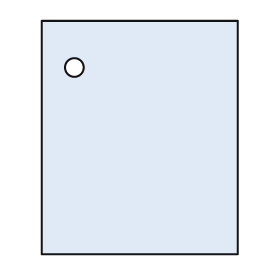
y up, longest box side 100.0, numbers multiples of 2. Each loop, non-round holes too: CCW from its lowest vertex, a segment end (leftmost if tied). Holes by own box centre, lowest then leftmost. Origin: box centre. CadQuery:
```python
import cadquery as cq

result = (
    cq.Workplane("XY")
    .moveTo(-42.0, -50.0)
    .lineTo(42.0, -50.0)
    .lineTo(42.0, 50.0)
    .lineTo(-42.0, 50.0)
    .close()
    .moveTo(-28.0, 30.0)
    .circle(4.0)
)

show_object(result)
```